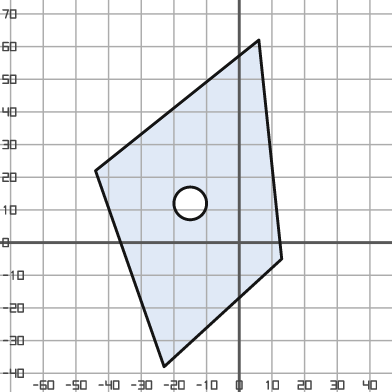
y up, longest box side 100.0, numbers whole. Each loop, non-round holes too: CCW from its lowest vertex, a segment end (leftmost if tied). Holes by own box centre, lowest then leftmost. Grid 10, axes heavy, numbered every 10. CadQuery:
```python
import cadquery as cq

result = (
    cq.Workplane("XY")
    .moveTo(-23.0, -38.0)
    .lineTo(13.0, -5.0)
    .lineTo(6.0, 62.0)
    .lineTo(-44.0, 22.0)
    .close()
    .moveTo(-15.0, 12.0)
    .circle(5.0)
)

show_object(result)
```